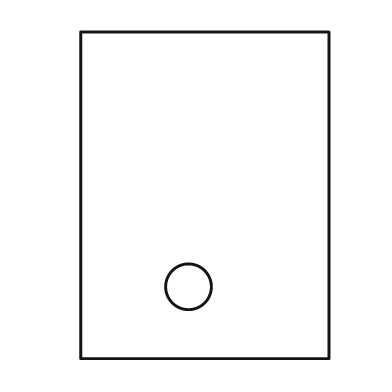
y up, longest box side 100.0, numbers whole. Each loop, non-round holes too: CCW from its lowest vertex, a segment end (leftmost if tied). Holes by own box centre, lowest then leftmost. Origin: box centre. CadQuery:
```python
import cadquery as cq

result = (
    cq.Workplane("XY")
    .moveTo(-38.0, -50.0)
    .lineTo(38.0, -50.0)
    .lineTo(38.0, 50.0)
    .lineTo(-38.0, 50.0)
    .close()
    .moveTo(-5.0, -28.0)
    .circle(7.0)
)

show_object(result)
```